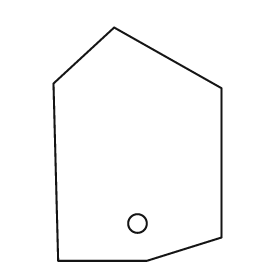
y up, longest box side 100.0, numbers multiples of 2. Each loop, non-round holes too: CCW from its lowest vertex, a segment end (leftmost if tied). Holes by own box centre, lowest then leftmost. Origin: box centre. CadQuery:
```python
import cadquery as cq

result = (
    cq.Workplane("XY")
    .moveTo(-34.0, -50.0)
    .lineTo(4.0, -50.0)
    .lineTo(36.0, -40.0)
    .lineTo(36.0, 24.0)
    .lineTo(-10.0, 50.0)
    .lineTo(-36.0, 26.0)
    .close()
    .moveTo(0.0, -34.0)
    .circle(4.0)
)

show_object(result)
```